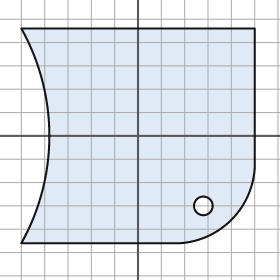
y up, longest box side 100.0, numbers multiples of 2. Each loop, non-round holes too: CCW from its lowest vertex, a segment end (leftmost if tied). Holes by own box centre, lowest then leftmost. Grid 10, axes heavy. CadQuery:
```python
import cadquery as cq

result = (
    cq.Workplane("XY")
    .moveTo(-50.0, -46.0)
    .lineTo(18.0, -46.0)
    .threePointArc((40.0, -36.0), (50.0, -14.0))
    .lineTo(50.0, 46.0)
    .lineTo(-50.0, 46.0)
    .threePointArc((-38.0, 0.0), (-50.0, -46.0))
    .close()
    .moveTo(28.0, -30.0)
    .circle(4.0)
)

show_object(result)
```